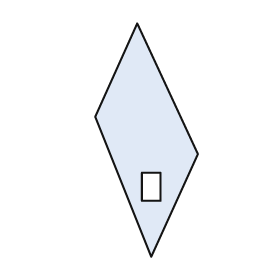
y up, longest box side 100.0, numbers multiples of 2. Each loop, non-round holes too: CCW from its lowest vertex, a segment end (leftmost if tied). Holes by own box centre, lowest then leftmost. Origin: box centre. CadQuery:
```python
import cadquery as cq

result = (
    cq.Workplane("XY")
    .moveTo(2.0, -50.0)
    .lineTo(22.0, -6.0)
    .lineTo(-4.0, 50.0)
    .lineTo(-22.0, 10.0)
    .close()
    .moveTo(-2.0, -26.0)
    .lineTo(6.0, -26.0)
    .lineTo(6.0, -14.0)
    .lineTo(-2.0, -14.0)
    .close()
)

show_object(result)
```